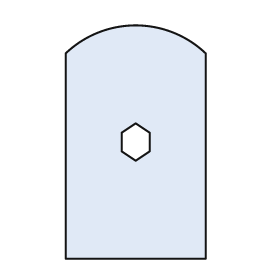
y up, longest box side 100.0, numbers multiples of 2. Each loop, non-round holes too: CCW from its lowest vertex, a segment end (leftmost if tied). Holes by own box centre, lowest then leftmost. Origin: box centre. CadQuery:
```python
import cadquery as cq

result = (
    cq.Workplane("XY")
    .moveTo(-30.0, -50.0)
    .lineTo(30.0, -50.0)
    .lineTo(30.0, 38.0)
    .threePointArc((0.0, 50.0), (-30.0, 38.0))
    .close()
    .moveTo(0.0, -8.0)
    .lineTo(6.0, -4.0)
    .lineTo(6.0, 4.0)
    .lineTo(0.0, 8.0)
    .lineTo(-6.0, 4.0)
    .lineTo(-6.0, -4.0)
    .close()
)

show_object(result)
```